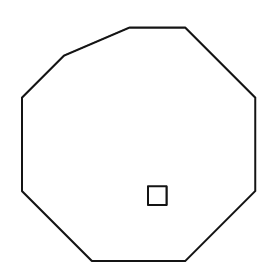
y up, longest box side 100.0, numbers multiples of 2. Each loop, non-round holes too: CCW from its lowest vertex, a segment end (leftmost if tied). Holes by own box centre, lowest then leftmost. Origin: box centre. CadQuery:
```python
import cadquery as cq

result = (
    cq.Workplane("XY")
    .moveTo(-20.0, -50.0)
    .lineTo(20.0, -50.0)
    .lineTo(50.0, -20.0)
    .lineTo(50.0, 20.0)
    .lineTo(20.0, 50.0)
    .lineTo(-4.0, 50.0)
    .lineTo(-32.0, 38.0)
    .lineTo(-50.0, 20.0)
    .lineTo(-50.0, -20.0)
    .close()
    .moveTo(4.0, -26.0)
    .lineTo(12.0, -26.0)
    .lineTo(12.0, -18.0)
    .lineTo(4.0, -18.0)
    .close()
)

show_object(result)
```